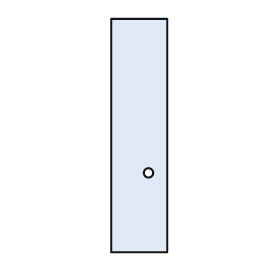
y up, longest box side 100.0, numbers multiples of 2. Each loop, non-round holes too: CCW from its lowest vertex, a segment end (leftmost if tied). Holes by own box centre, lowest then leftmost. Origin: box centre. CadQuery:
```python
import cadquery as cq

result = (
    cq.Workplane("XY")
    .moveTo(-12.0, -50.0)
    .lineTo(12.0, -50.0)
    .lineTo(12.0, 50.0)
    .lineTo(-12.0, 50.0)
    .close()
    .moveTo(4.0, -16.0)
    .circle(2.0)
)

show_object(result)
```